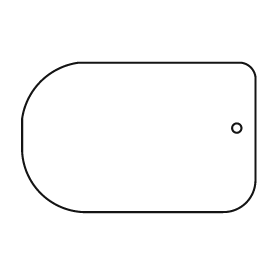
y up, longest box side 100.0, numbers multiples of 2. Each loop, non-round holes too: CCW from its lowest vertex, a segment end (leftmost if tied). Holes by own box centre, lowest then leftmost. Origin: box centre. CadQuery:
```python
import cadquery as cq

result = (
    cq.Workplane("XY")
    .moveTo(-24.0, -32.0)
    .lineTo(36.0, -32.0)
    .threePointArc((46.0, -28.0), (50.0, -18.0))
    .lineTo(50.0, 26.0)
    .threePointArc((48.0, 30.0), (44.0, 32.0))
    .lineTo(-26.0, 32.0)
    .threePointArc((-42.0, 24.0), (-50.0, 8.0))
    .lineTo(-50.0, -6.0)
    .threePointArc((-42.0, -24.0), (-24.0, -32.0))
    .close()
    .moveTo(42.0, 4.0)
    .circle(2.0)
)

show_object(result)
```